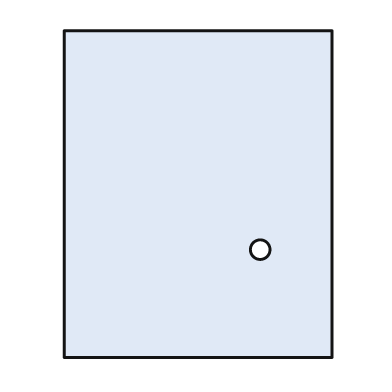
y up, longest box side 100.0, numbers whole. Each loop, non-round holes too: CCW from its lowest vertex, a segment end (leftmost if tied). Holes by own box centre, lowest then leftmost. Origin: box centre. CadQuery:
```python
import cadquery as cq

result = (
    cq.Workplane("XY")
    .moveTo(-41.0, -50.0)
    .lineTo(41.0, -50.0)
    .lineTo(41.0, 50.0)
    .lineTo(-41.0, 50.0)
    .close()
    .moveTo(19.0, -17.0)
    .circle(3.0)
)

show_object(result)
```